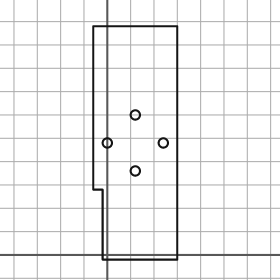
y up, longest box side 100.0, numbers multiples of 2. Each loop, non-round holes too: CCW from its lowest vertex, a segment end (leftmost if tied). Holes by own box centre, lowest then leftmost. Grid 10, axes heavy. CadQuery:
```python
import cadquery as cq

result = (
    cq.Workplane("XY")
    .moveTo(-2.0, -2.0)
    .lineTo(30.0, -2.0)
    .lineTo(30.0, 98.0)
    .lineTo(-6.0, 98.0)
    .lineTo(-6.0, 28.0)
    .lineTo(-2.0, 28.0)
    .close()
    .moveTo(12.0, 36.0)
    .circle(2.0)
    .moveTo(0.0, 48.0)
    .circle(2.0)
    .moveTo(24.0, 48.0)
    .circle(2.0)
    .moveTo(12.0, 60.0)
    .circle(2.0)
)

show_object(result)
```